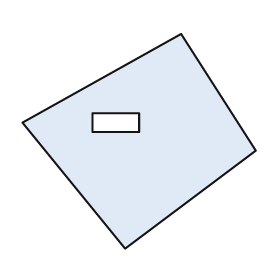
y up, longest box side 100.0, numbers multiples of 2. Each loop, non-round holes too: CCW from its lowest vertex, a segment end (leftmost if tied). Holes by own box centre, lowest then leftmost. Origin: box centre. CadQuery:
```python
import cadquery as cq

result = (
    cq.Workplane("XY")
    .moveTo(-6.0, -46.0)
    .lineTo(50.0, -4.0)
    .lineTo(18.0, 46.0)
    .lineTo(-50.0, 8.0)
    .close()
    .moveTo(-20.0, 4.0)
    .lineTo(0.0, 4.0)
    .lineTo(0.0, 12.0)
    .lineTo(-20.0, 12.0)
    .close()
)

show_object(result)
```